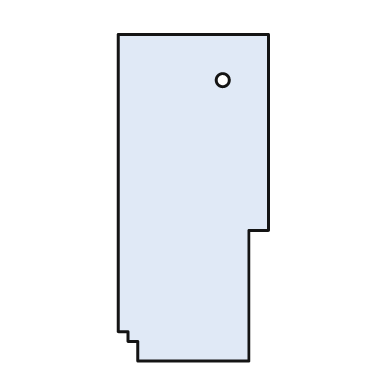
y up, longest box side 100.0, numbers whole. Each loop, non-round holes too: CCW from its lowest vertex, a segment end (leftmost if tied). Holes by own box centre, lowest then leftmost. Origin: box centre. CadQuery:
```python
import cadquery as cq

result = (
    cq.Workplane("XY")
    .moveTo(-17.0, -50.0)
    .lineTo(17.0, -50.0)
    .lineTo(17.0, -10.0)
    .lineTo(23.0, -10.0)
    .lineTo(23.0, 50.0)
    .lineTo(-23.0, 50.0)
    .lineTo(-23.0, -41.0)
    .lineTo(-20.0, -41.0)
    .lineTo(-20.0, -44.0)
    .lineTo(-17.0, -44.0)
    .close()
    .moveTo(9.0, 36.0)
    .circle(2.0)
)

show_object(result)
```